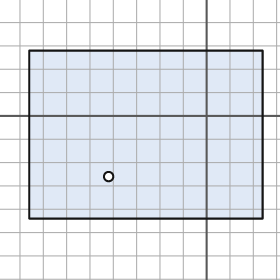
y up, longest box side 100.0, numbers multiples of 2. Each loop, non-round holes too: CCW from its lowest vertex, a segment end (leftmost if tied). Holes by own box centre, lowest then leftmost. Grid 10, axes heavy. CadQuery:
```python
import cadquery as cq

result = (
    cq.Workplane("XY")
    .moveTo(-76.0, -44.0)
    .lineTo(24.0, -44.0)
    .lineTo(24.0, 28.0)
    .lineTo(-76.0, 28.0)
    .close()
    .moveTo(-42.0, -26.0)
    .circle(2.0)
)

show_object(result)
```